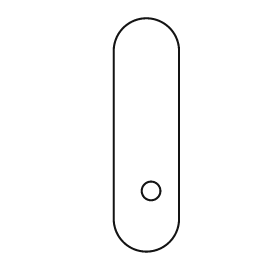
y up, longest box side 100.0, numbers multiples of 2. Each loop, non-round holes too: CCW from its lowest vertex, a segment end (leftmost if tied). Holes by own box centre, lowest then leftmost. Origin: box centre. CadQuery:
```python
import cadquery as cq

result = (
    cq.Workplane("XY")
    .moveTo(-14.0, -36.0)
    .threePointArc((0.0, -50.0), (14.0, -36.0))
    .lineTo(14.0, 36.0)
    .threePointArc((0.0, 50.0), (-14.0, 36.0))
    .close()
    .moveTo(2.0, -24.0)
    .circle(4.0)
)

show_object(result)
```